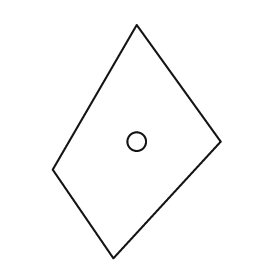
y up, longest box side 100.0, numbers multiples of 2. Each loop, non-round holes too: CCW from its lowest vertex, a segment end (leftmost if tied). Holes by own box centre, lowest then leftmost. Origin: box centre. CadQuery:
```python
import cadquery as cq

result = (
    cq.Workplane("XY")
    .moveTo(-10.0, -50.0)
    .lineTo(36.0, 0.0)
    .lineTo(0.0, 50.0)
    .lineTo(-36.0, -12.0)
    .close()
    .moveTo(0.0, 0.0)
    .circle(4.0)
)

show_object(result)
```